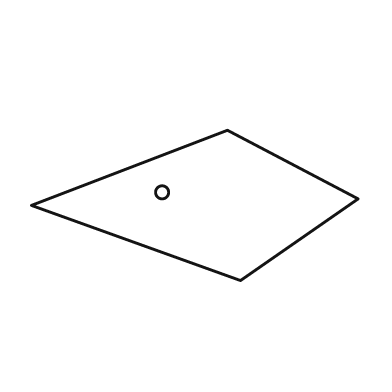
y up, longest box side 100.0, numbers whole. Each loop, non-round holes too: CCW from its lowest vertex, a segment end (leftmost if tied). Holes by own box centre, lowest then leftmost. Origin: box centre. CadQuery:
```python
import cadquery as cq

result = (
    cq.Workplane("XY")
    .moveTo(14.0, -23.0)
    .lineTo(50.0, 2.0)
    .lineTo(10.0, 23.0)
    .lineTo(-50.0, 0.0)
    .close()
    .moveTo(-10.0, 4.0)
    .circle(2.0)
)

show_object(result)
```